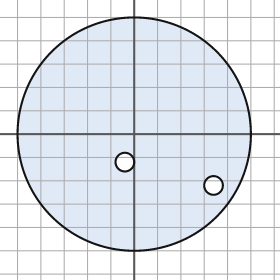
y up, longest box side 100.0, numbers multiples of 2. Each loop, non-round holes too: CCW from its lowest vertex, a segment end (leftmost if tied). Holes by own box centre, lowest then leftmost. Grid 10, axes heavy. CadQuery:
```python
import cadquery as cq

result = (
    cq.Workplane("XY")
    .moveTo(0.0, 0.0)
    .circle(50.0)
    .moveTo(34.0, -22.0)
    .circle(4.0)
    .moveTo(-4.0, -12.0)
    .circle(4.0)
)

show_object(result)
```